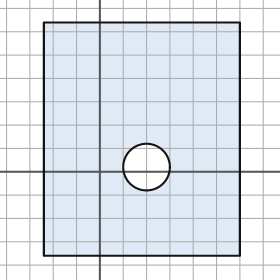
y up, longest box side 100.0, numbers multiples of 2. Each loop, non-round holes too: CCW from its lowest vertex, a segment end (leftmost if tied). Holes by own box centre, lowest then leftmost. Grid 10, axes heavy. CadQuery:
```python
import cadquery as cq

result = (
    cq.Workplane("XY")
    .moveTo(-24.0, -36.0)
    .lineTo(60.0, -36.0)
    .lineTo(60.0, 64.0)
    .lineTo(-24.0, 64.0)
    .close()
    .moveTo(20.0, 2.0)
    .circle(10.0)
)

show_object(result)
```